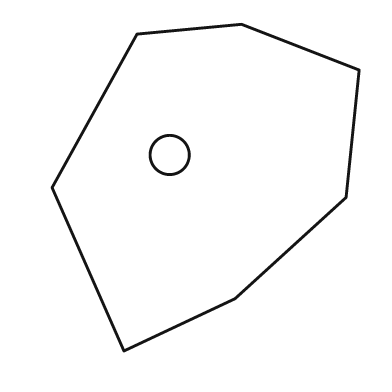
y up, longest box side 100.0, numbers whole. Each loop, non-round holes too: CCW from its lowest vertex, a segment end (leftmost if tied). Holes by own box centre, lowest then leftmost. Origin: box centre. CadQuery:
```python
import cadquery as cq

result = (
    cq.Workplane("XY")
    .moveTo(-25.0, -50.0)
    .lineTo(9.0, -34.0)
    .lineTo(43.0, -3.0)
    .lineTo(47.0, 36.0)
    .lineTo(11.0, 50.0)
    .lineTo(-21.0, 47.0)
    .lineTo(-47.0, 0.0)
    .close()
    .moveTo(-11.0, 10.0)
    .circle(6.0)
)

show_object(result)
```